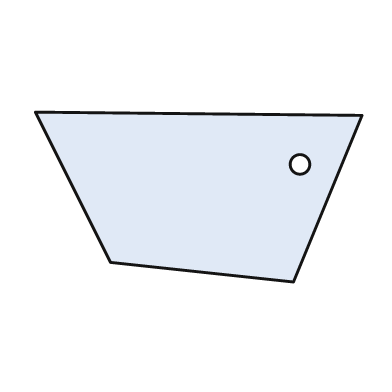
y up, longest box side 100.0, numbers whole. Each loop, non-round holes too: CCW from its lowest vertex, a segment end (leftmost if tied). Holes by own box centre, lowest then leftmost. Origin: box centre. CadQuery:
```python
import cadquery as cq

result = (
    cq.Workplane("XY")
    .moveTo(29.0, -26.0)
    .lineTo(50.0, 25.0)
    .lineTo(-50.0, 26.0)
    .lineTo(-27.0, -20.0)
    .close()
    .moveTo(31.0, 10.0)
    .circle(3.0)
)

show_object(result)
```